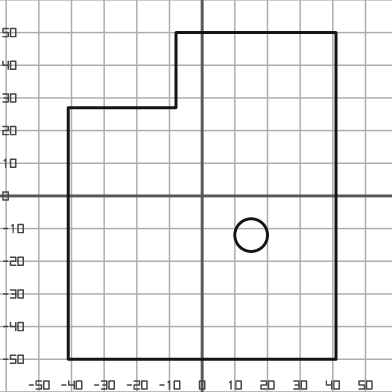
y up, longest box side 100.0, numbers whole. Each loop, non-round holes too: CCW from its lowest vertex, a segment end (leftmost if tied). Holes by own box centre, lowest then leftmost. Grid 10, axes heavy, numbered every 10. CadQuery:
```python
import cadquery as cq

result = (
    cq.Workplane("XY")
    .moveTo(-41.0, -50.0)
    .lineTo(41.0, -50.0)
    .lineTo(41.0, 50.0)
    .lineTo(-8.0, 50.0)
    .lineTo(-8.0, 27.0)
    .lineTo(-41.0, 27.0)
    .close()
    .moveTo(15.0, -12.0)
    .circle(5.0)
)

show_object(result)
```